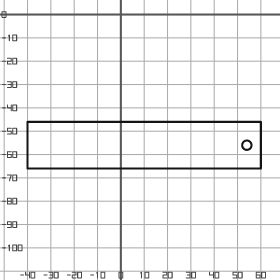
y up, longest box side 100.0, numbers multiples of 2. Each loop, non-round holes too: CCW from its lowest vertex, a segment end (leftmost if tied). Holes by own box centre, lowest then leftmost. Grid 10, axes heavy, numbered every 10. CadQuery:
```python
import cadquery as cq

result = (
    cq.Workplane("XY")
    .moveTo(-40.0, -66.0)
    .lineTo(60.0, -66.0)
    .lineTo(60.0, -46.0)
    .lineTo(-40.0, -46.0)
    .close()
    .moveTo(54.0, -56.0)
    .circle(2.0)
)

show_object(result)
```